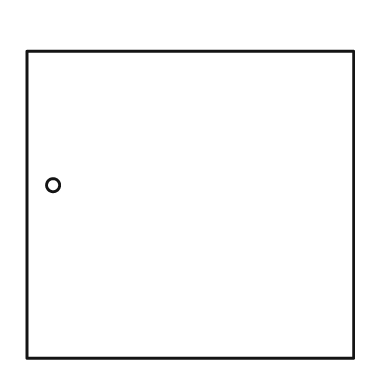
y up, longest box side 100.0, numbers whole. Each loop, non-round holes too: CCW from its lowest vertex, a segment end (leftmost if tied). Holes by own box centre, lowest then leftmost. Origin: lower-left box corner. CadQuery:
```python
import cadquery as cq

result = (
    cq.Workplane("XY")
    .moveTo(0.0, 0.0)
    .lineTo(100.0, 0.0)
    .lineTo(100.0, 94.0)
    .lineTo(0.0, 94.0)
    .close()
    .moveTo(8.0, 53.0)
    .circle(2.0)
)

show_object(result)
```